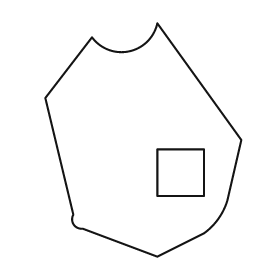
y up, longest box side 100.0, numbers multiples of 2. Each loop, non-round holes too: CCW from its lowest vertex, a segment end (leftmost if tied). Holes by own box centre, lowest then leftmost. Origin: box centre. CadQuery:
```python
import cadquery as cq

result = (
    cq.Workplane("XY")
    .moveTo(6.0, -50.0)
    .lineTo(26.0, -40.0)
    .threePointArc((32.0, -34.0), (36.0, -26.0))
    .lineTo(42.0, 0.0)
    .lineTo(6.0, 50.0)
    .threePointArc((-6.0, 38.0), (-22.0, 44.0))
    .lineTo(-42.0, 18.0)
    .lineTo(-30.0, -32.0)
    .threePointArc((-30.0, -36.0), (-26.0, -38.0))
    .close()
    .moveTo(6.0, -24.0)
    .lineTo(26.0, -24.0)
    .lineTo(26.0, -4.0)
    .lineTo(6.0, -4.0)
    .close()
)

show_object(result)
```